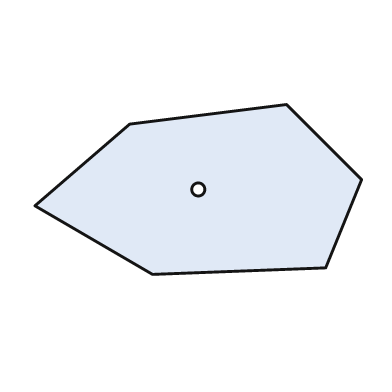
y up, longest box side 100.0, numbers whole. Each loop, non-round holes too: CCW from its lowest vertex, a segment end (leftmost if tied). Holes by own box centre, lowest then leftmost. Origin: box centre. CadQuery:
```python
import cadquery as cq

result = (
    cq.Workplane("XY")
    .moveTo(-14.0, -26.0)
    .lineTo(39.0, -24.0)
    .lineTo(50.0, 3.0)
    .lineTo(27.0, 26.0)
    .lineTo(-21.0, 20.0)
    .lineTo(-50.0, -5.0)
    .close()
    .moveTo(0.0, 0.0)
    .circle(2.0)
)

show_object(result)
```